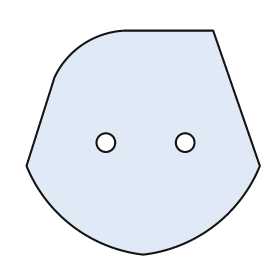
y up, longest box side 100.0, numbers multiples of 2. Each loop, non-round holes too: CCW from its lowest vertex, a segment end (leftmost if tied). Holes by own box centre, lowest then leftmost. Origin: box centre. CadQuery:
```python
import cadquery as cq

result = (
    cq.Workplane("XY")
    .moveTo(0.0, -48.0)
    .threePointArc((30.0, -36.0), (50.0, -10.0))
    .lineTo(30.0, 48.0)
    .lineTo(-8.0, 48.0)
    .threePointArc((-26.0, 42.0), (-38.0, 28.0))
    .lineTo(-50.0, -10.0)
    .threePointArc((-30.0, -36.0), (0.0, -48.0))
    .close()
    .moveTo(-16.0, 0.0)
    .circle(4.0)
    .moveTo(18.0, 0.0)
    .circle(4.0)
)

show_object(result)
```